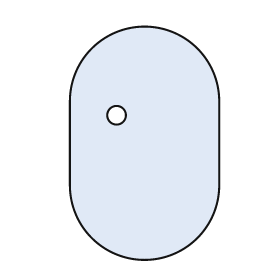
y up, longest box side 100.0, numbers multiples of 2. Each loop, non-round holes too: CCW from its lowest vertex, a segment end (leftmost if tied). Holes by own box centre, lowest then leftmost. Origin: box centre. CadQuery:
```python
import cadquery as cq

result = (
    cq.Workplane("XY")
    .moveTo(-32.0, -18.0)
    .threePointArc((0.0, -50.0), (32.0, -18.0))
    .lineTo(32.0, 18.0)
    .threePointArc((0.0, 50.0), (-32.0, 18.0))
    .close()
    .moveTo(-12.0, 12.0)
    .circle(4.0)
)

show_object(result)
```